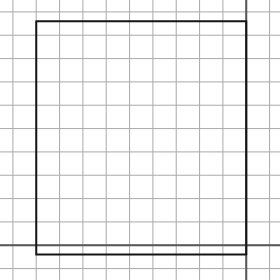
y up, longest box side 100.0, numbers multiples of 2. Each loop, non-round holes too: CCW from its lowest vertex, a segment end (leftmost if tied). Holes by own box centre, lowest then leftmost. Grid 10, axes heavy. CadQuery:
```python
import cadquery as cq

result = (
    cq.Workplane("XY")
    .moveTo(-90.0, -4.0)
    .lineTo(0.0, -4.0)
    .lineTo(0.0, 96.0)
    .lineTo(-90.0, 96.0)
    .close()
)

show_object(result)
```